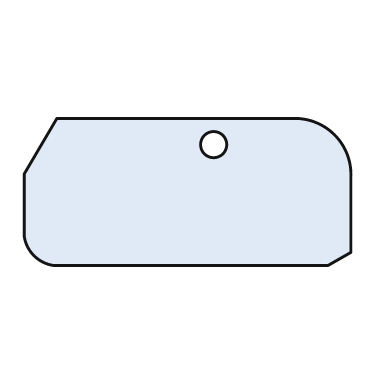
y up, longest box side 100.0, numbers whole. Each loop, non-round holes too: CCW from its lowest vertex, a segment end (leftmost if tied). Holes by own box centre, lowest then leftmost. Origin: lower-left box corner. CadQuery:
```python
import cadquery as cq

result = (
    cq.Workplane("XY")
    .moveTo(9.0, 0.0)
    .lineTo(93.0, 0.0)
    .lineTo(100.0, 4.0)
    .lineTo(100.0, 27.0)
    .threePointArc((95.0, 40.0), (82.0, 45.0))
    .lineTo(10.0, 45.0)
    .lineTo(0.0, 28.0)
    .lineTo(0.0, 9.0)
    .threePointArc((3.0, 3.0), (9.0, 0.0))
    .close()
    .moveTo(58.0, 37.0)
    .circle(4.0)
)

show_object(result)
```